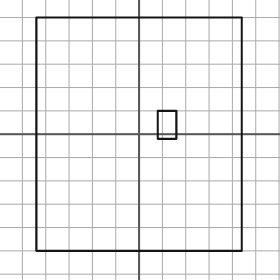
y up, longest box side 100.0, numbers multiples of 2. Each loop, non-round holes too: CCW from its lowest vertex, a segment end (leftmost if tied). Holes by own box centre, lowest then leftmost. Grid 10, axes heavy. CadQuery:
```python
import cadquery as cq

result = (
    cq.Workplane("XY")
    .moveTo(-44.0, -50.0)
    .lineTo(44.0, -50.0)
    .lineTo(44.0, 50.0)
    .lineTo(-44.0, 50.0)
    .close()
    .moveTo(8.0, -2.0)
    .lineTo(16.0, -2.0)
    .lineTo(16.0, 10.0)
    .lineTo(8.0, 10.0)
    .close()
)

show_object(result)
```